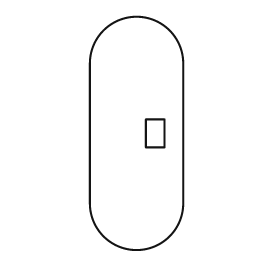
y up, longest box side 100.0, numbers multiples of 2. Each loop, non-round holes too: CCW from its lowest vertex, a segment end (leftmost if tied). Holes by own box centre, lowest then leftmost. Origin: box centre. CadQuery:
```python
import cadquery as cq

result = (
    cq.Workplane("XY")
    .moveTo(-20.0, -30.0)
    .threePointArc((0.0, -50.0), (20.0, -30.0))
    .lineTo(20.0, 30.0)
    .threePointArc((0.0, 50.0), (-20.0, 30.0))
    .close()
    .moveTo(4.0, -6.0)
    .lineTo(12.0, -6.0)
    .lineTo(12.0, 6.0)
    .lineTo(4.0, 6.0)
    .close()
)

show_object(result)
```